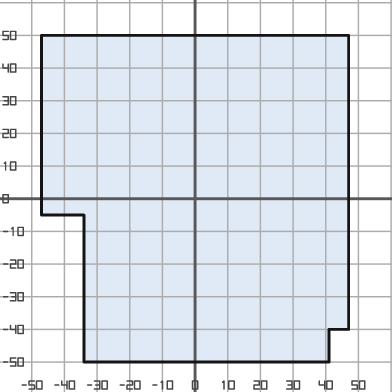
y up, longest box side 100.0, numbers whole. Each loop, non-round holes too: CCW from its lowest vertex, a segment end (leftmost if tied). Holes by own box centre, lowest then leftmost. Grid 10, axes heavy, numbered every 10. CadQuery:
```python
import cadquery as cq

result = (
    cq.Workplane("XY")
    .moveTo(-34.0, -50.0)
    .lineTo(41.0, -50.0)
    .lineTo(41.0, -40.0)
    .lineTo(47.0, -40.0)
    .lineTo(47.0, 50.0)
    .lineTo(-47.0, 50.0)
    .lineTo(-47.0, -5.0)
    .lineTo(-34.0, -5.0)
    .close()
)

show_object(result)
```